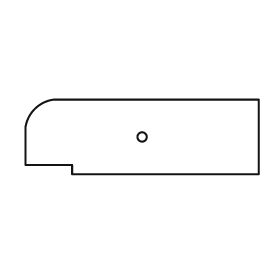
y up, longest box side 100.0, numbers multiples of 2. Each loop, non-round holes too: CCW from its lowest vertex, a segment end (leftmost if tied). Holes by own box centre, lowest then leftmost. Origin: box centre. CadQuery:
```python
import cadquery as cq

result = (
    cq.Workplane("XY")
    .moveTo(-30.0, -16.0)
    .lineTo(50.0, -16.0)
    .lineTo(50.0, 16.0)
    .lineTo(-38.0, 16.0)
    .threePointArc((-46.0, 12.0), (-50.0, 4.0))
    .lineTo(-50.0, -12.0)
    .lineTo(-30.0, -12.0)
    .close()
    .moveTo(0.0, 0.0)
    .circle(2.0)
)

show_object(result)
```